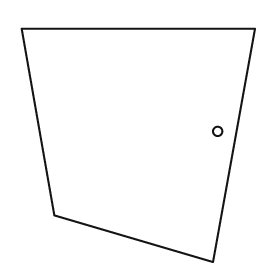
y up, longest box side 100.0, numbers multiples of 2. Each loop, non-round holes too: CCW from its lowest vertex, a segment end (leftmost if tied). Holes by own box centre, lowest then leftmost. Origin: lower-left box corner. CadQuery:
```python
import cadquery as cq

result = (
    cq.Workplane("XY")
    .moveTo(82.0, 0.0)
    .lineTo(100.0, 100.0)
    .lineTo(0.0, 100.0)
    .lineTo(14.0, 20.0)
    .close()
    .moveTo(84.0, 56.0)
    .circle(2.0)
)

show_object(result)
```